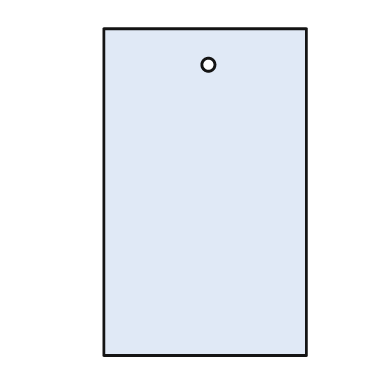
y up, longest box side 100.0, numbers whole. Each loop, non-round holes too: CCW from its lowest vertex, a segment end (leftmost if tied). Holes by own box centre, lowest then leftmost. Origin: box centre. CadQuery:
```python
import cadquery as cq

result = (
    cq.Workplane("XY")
    .moveTo(-31.0, -50.0)
    .lineTo(31.0, -50.0)
    .lineTo(31.0, 50.0)
    .lineTo(-31.0, 50.0)
    .close()
    .moveTo(1.0, 39.0)
    .circle(2.0)
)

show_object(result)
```